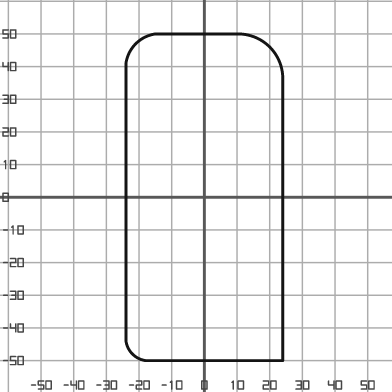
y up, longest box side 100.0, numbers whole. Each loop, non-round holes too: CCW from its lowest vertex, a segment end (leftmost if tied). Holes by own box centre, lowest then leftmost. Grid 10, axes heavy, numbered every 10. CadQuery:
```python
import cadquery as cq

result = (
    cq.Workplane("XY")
    .moveTo(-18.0, -50.0)
    .lineTo(24.0, -50.0)
    .lineTo(24.0, 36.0)
    .threePointArc((20.0, 46.0), (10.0, 50.0))
    .lineTo(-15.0, 50.0)
    .threePointArc((-21.0, 47.0), (-24.0, 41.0))
    .lineTo(-24.0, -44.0)
    .threePointArc((-22.0, -48.0), (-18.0, -50.0))
    .close()
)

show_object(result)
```